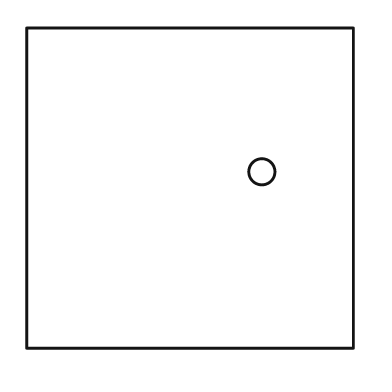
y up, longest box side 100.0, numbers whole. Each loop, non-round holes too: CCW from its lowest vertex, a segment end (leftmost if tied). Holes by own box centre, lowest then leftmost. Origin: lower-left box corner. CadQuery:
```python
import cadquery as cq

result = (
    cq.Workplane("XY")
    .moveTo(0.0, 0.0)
    .lineTo(100.0, 0.0)
    .lineTo(100.0, 98.0)
    .lineTo(0.0, 98.0)
    .close()
    .moveTo(72.0, 54.0)
    .circle(4.0)
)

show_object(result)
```